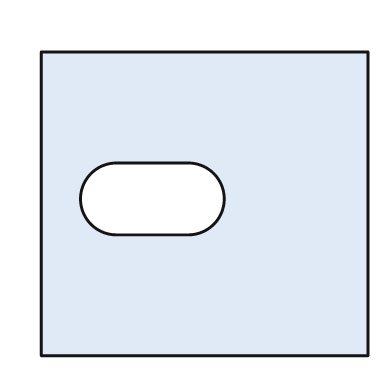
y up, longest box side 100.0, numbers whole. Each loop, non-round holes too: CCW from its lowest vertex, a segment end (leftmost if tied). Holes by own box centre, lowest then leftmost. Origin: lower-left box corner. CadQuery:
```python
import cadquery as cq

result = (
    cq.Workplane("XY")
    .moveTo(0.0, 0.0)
    .lineTo(100.0, 0.0)
    .lineTo(100.0, 93.0)
    .lineTo(0.0, 93.0)
    .close()
    .moveTo(23.0, 37.0)
    .lineTo(45.0, 37.0)
    .threePointArc((56.0, 48.0), (45.0, 59.0))
    .lineTo(23.0, 59.0)
    .threePointArc((12.0, 48.0), (23.0, 37.0))
    .close()
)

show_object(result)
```